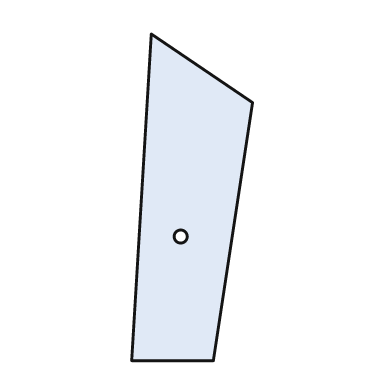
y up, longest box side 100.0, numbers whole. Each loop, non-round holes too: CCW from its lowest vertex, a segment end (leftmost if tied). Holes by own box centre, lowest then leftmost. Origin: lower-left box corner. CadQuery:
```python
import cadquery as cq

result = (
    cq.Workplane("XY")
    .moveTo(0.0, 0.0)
    .lineTo(25.0, 0.0)
    .lineTo(37.0, 79.0)
    .lineTo(6.0, 100.0)
    .close()
    .moveTo(15.0, 38.0)
    .circle(2.0)
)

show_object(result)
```